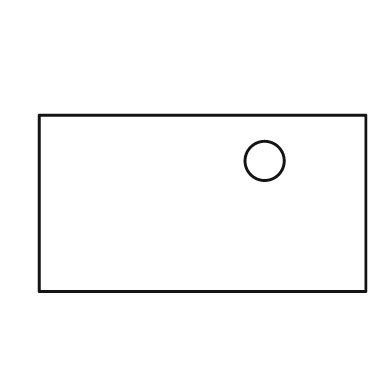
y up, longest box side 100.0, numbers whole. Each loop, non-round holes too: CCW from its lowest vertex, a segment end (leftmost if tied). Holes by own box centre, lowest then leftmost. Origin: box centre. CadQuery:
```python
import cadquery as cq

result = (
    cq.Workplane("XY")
    .moveTo(-50.0, -27.0)
    .lineTo(50.0, -27.0)
    .lineTo(50.0, 27.0)
    .lineTo(-50.0, 27.0)
    .close()
    .moveTo(19.0, 13.0)
    .circle(6.0)
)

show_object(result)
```